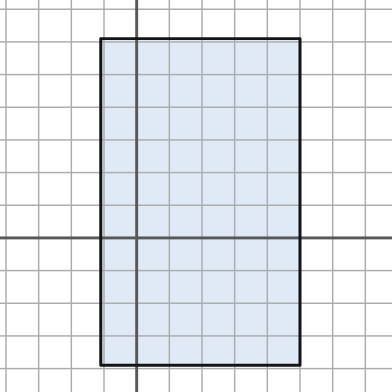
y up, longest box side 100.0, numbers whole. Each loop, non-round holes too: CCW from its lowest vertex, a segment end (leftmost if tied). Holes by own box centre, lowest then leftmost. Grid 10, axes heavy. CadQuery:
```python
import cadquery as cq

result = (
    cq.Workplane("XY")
    .moveTo(-11.0, -39.0)
    .lineTo(50.0, -39.0)
    .lineTo(50.0, 61.0)
    .lineTo(-11.0, 61.0)
    .close()
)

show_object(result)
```